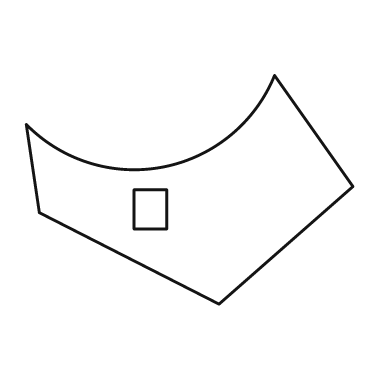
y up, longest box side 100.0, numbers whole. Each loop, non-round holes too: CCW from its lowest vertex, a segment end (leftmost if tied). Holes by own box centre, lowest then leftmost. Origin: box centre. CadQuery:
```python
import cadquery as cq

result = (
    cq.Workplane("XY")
    .moveTo(9.0, -35.0)
    .lineTo(50.0, 1.0)
    .lineTo(26.0, 35.0)
    .threePointArc((-8.0, 7.0), (-50.0, 20.0))
    .lineTo(-46.0, -7.0)
    .close()
    .moveTo(-17.0, -12.0)
    .lineTo(-7.0, -12.0)
    .lineTo(-7.0, 0.0)
    .lineTo(-17.0, 0.0)
    .close()
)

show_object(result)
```